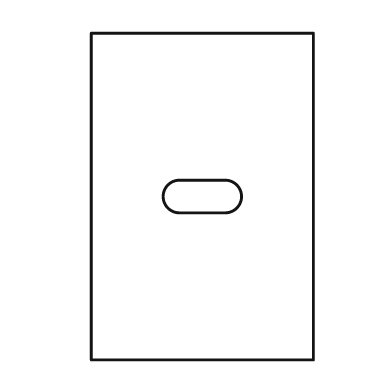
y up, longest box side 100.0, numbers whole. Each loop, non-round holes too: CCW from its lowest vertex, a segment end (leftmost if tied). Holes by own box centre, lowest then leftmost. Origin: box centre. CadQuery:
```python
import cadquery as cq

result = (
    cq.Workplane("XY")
    .moveTo(-34.0, -50.0)
    .lineTo(34.0, -50.0)
    .lineTo(34.0, 50.0)
    .lineTo(-34.0, 50.0)
    .close()
    .moveTo(-7.0, -5.0)
    .lineTo(7.0, -5.0)
    .threePointArc((12.0, 0.0), (7.0, 5.0))
    .lineTo(-7.0, 5.0)
    .threePointArc((-12.0, 0.0), (-7.0, -5.0))
    .close()
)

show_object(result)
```